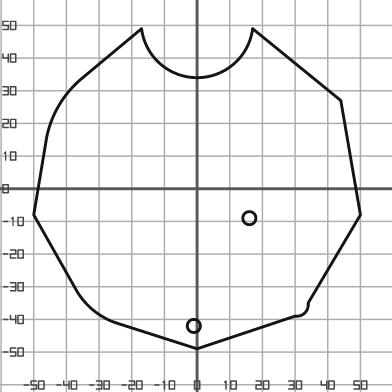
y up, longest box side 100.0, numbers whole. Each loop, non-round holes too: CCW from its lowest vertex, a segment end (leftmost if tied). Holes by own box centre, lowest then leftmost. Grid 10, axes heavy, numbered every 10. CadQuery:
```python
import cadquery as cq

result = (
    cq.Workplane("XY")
    .moveTo(0.0, -49.0)
    .lineTo(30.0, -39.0)
    .threePointArc((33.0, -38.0), (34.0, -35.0))
    .lineTo(50.0, -8.0)
    .lineTo(44.0, 27.0)
    .lineTo(17.0, 49.0)
    .threePointArc((0.0, 34.0), (-17.0, 49.0))
    .lineTo(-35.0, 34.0)
    .threePointArc((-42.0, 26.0), (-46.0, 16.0))
    .lineTo(-50.0, -8.0)
    .lineTo(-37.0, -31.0)
    .threePointArc((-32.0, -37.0), (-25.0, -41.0))
    .close()
    .moveTo(-1.0, -42.0)
    .circle(2.0)
    .moveTo(16.0, -9.0)
    .circle(2.0)
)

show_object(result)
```